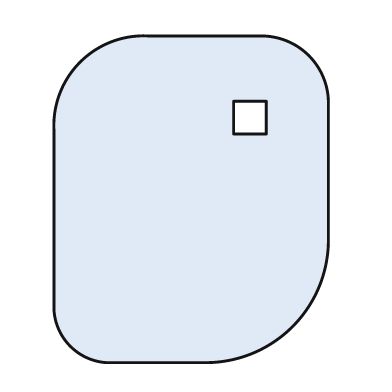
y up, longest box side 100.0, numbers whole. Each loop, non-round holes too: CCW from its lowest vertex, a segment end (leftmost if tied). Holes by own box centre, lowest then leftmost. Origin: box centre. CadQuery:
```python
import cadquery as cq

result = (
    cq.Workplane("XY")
    .moveTo(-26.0, -50.0)
    .lineTo(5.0, -50.0)
    .threePointArc((31.0, -39.0), (42.0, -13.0))
    .lineTo(42.0, 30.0)
    .threePointArc((36.0, 44.0), (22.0, 50.0))
    .lineTo(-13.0, 50.0)
    .threePointArc((-34.0, 42.0), (-42.0, 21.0))
    .lineTo(-42.0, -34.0)
    .threePointArc((-37.0, -45.0), (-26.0, -50.0))
    .close()
    .moveTo(13.0, 20.0)
    .lineTo(23.0, 20.0)
    .lineTo(23.0, 30.0)
    .lineTo(13.0, 30.0)
    .close()
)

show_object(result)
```